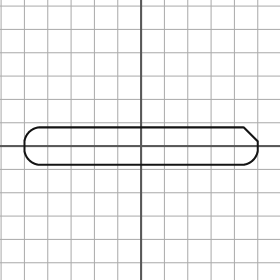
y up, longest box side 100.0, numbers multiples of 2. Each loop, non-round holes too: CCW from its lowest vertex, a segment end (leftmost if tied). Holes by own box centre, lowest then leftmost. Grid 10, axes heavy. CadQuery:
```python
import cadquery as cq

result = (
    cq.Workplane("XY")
    .moveTo(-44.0, -8.0)
    .lineTo(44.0, -8.0)
    .threePointArc((48.0, -6.0), (50.0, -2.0))
    .lineTo(50.0, 2.0)
    .lineTo(44.0, 8.0)
    .lineTo(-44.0, 8.0)
    .threePointArc((-48.0, 6.0), (-50.0, 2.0))
    .lineTo(-50.0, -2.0)
    .threePointArc((-48.0, -6.0), (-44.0, -8.0))
    .close()
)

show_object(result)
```